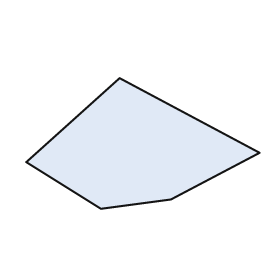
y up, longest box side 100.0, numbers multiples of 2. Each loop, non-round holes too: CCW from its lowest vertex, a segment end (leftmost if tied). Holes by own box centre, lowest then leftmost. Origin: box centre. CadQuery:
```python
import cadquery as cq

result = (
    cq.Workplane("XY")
    .moveTo(-18.0, -28.0)
    .lineTo(12.0, -24.0)
    .lineTo(50.0, -4.0)
    .lineTo(-10.0, 28.0)
    .lineTo(-50.0, -8.0)
    .close()
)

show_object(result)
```